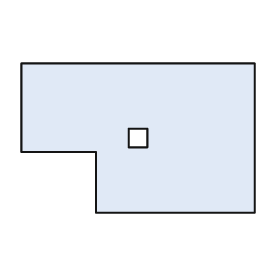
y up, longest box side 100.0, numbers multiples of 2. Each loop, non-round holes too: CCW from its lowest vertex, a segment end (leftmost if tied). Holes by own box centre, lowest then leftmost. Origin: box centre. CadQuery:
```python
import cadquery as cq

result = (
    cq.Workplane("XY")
    .moveTo(-18.0, -32.0)
    .lineTo(50.0, -32.0)
    .lineTo(50.0, 32.0)
    .lineTo(-50.0, 32.0)
    .lineTo(-50.0, -6.0)
    .lineTo(-18.0, -6.0)
    .close()
    .moveTo(-4.0, -4.0)
    .lineTo(4.0, -4.0)
    .lineTo(4.0, 4.0)
    .lineTo(-4.0, 4.0)
    .close()
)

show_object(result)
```